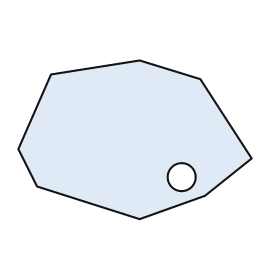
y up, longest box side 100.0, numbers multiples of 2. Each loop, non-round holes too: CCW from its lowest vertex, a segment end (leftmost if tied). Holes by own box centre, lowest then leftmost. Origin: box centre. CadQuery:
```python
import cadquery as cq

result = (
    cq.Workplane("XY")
    .moveTo(2.0, -34.0)
    .lineTo(30.0, -24.0)
    .lineTo(50.0, -8.0)
    .lineTo(28.0, 26.0)
    .lineTo(2.0, 34.0)
    .lineTo(-36.0, 28.0)
    .lineTo(-50.0, -4.0)
    .lineTo(-42.0, -20.0)
    .close()
    .moveTo(20.0, -16.0)
    .circle(6.0)
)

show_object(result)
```